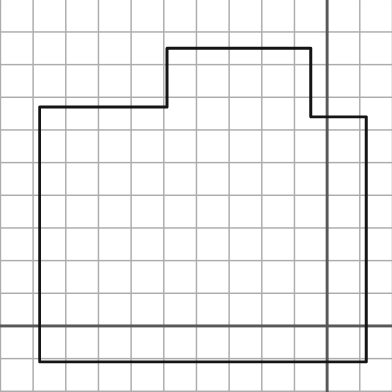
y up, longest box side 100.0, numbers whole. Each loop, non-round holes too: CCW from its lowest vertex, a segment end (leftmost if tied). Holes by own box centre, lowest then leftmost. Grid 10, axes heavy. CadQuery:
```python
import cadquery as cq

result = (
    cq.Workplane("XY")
    .moveTo(-88.0, -11.0)
    .lineTo(12.0, -11.0)
    .lineTo(12.0, 64.0)
    .lineTo(-5.0, 64.0)
    .lineTo(-5.0, 85.0)
    .lineTo(-49.0, 85.0)
    .lineTo(-49.0, 67.0)
    .lineTo(-88.0, 67.0)
    .close()
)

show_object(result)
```